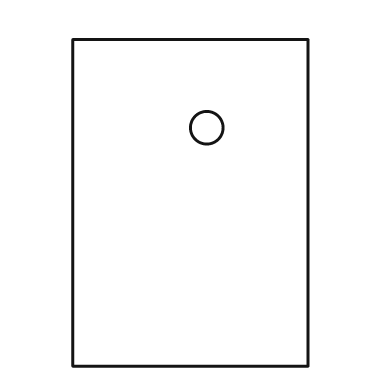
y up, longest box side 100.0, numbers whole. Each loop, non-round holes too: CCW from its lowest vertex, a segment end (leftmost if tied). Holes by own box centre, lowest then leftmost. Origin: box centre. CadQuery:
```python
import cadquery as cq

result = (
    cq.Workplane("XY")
    .moveTo(-36.0, -50.0)
    .lineTo(36.0, -50.0)
    .lineTo(36.0, 50.0)
    .lineTo(-36.0, 50.0)
    .close()
    .moveTo(5.0, 23.0)
    .circle(5.0)
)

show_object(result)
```